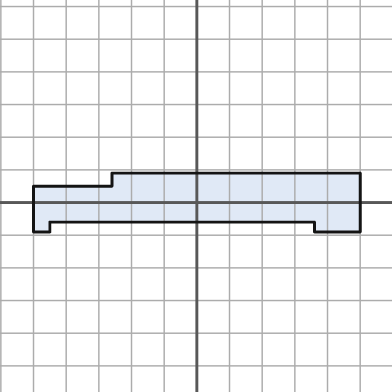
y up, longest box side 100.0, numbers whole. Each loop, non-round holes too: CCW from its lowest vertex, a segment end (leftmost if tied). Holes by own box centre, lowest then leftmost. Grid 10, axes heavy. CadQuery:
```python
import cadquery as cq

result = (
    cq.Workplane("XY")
    .moveTo(-50.0, -9.0)
    .lineTo(-45.0, -9.0)
    .lineTo(-45.0, -6.0)
    .lineTo(36.0, -6.0)
    .lineTo(36.0, -9.0)
    .lineTo(50.0, -9.0)
    .lineTo(50.0, 9.0)
    .lineTo(-26.0, 9.0)
    .lineTo(-26.0, 5.0)
    .lineTo(-50.0, 5.0)
    .close()
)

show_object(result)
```